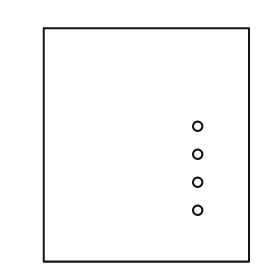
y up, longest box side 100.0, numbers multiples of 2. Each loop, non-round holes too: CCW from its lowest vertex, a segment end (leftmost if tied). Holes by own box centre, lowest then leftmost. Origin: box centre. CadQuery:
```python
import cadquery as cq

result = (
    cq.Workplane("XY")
    .moveTo(-44.0, -50.0)
    .lineTo(44.0, -50.0)
    .lineTo(44.0, 50.0)
    .lineTo(-44.0, 50.0)
    .close()
    .moveTo(22.0, -28.0)
    .circle(2.0)
    .moveTo(22.0, -16.0)
    .circle(2.0)
    .moveTo(22.0, -4.0)
    .circle(2.0)
    .moveTo(22.0, 8.0)
    .circle(2.0)
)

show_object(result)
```